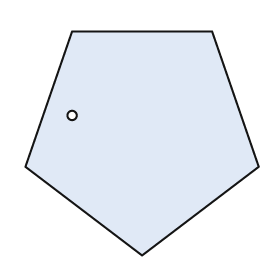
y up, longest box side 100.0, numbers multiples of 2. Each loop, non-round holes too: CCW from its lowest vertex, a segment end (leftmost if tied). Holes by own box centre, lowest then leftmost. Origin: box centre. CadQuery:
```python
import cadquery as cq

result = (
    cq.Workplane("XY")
    .moveTo(0.0, -48.0)
    .lineTo(50.0, -10.0)
    .lineTo(30.0, 48.0)
    .lineTo(-30.0, 48.0)
    .lineTo(-50.0, -10.0)
    .close()
    .moveTo(-30.0, 12.0)
    .circle(2.0)
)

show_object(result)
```